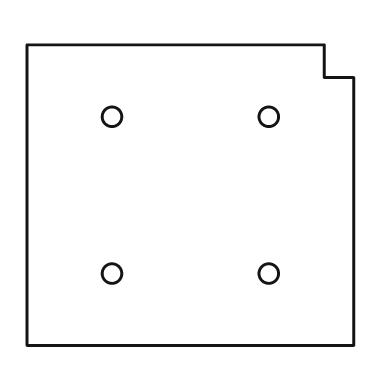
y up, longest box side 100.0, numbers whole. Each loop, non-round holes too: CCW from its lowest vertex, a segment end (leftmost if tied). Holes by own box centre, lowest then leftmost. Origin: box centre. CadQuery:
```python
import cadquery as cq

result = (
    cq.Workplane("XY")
    .moveTo(-50.0, -46.0)
    .lineTo(50.0, -46.0)
    .lineTo(50.0, 36.0)
    .lineTo(41.0, 36.0)
    .lineTo(41.0, 46.0)
    .lineTo(-50.0, 46.0)
    .close()
    .moveTo(-24.0, -24.0)
    .circle(3.0)
    .moveTo(24.0, -24.0)
    .circle(3.0)
    .moveTo(-24.0, 24.0)
    .circle(3.0)
    .moveTo(24.0, 24.0)
    .circle(3.0)
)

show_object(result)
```